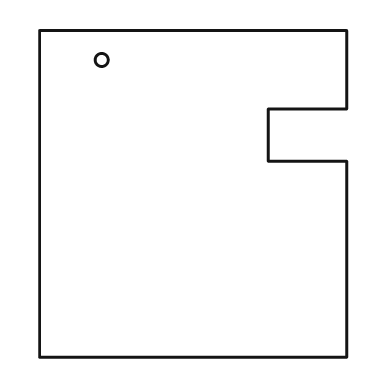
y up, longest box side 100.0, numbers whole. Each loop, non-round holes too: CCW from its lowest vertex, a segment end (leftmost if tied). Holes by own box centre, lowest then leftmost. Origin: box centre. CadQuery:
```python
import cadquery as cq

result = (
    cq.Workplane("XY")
    .moveTo(-47.0, -50.0)
    .lineTo(47.0, -50.0)
    .lineTo(47.0, 10.0)
    .lineTo(23.0, 10.0)
    .lineTo(23.0, 26.0)
    .lineTo(47.0, 26.0)
    .lineTo(47.0, 50.0)
    .lineTo(-47.0, 50.0)
    .close()
    .moveTo(-28.0, 41.0)
    .circle(2.0)
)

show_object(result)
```